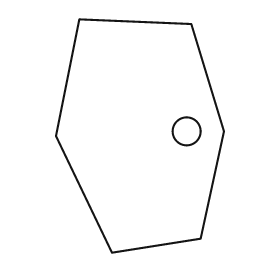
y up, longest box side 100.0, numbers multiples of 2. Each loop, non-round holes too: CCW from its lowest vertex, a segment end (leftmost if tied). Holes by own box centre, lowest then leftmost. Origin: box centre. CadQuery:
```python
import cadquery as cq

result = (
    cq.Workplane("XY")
    .moveTo(-12.0, -50.0)
    .lineTo(26.0, -44.0)
    .lineTo(36.0, 2.0)
    .lineTo(22.0, 48.0)
    .lineTo(-26.0, 50.0)
    .lineTo(-36.0, 0.0)
    .close()
    .moveTo(20.0, 2.0)
    .circle(6.0)
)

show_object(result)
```